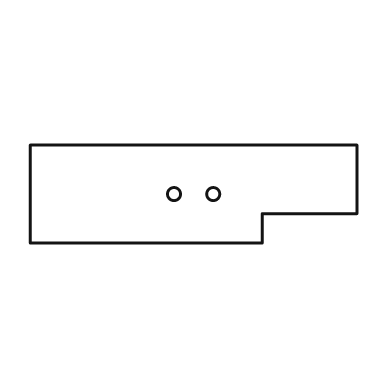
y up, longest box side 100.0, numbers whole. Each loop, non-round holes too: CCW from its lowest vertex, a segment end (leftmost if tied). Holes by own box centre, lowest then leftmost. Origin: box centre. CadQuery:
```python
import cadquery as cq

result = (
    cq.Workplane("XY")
    .moveTo(-50.0, -15.0)
    .lineTo(21.0, -15.0)
    .lineTo(21.0, -6.0)
    .lineTo(50.0, -6.0)
    .lineTo(50.0, 15.0)
    .lineTo(-50.0, 15.0)
    .close()
    .moveTo(-6.0, 0.0)
    .circle(2.0)
    .moveTo(6.0, 0.0)
    .circle(2.0)
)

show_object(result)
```